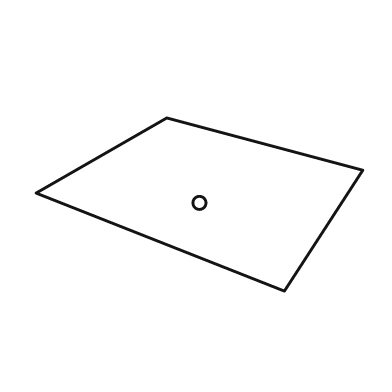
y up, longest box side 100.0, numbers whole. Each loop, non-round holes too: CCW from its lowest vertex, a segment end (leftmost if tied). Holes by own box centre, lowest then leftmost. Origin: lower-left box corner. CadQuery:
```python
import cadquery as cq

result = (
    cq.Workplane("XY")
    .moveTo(76.0, 0.0)
    .lineTo(100.0, 37.0)
    .lineTo(40.0, 53.0)
    .lineTo(0.0, 30.0)
    .close()
    .moveTo(50.0, 27.0)
    .circle(2.0)
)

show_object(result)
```